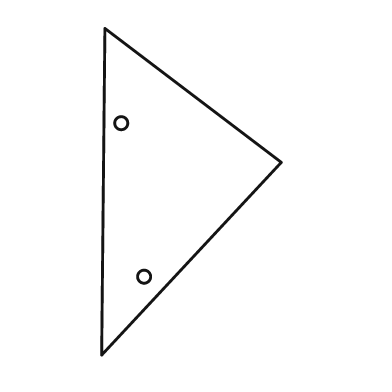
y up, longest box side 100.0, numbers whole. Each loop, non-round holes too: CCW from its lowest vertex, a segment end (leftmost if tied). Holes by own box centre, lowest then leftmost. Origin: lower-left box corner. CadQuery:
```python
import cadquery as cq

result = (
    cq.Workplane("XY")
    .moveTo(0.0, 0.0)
    .lineTo(55.0, 59.0)
    .lineTo(1.0, 100.0)
    .close()
    .moveTo(13.0, 24.0)
    .circle(2.0)
    .moveTo(6.0, 71.0)
    .circle(2.0)
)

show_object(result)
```